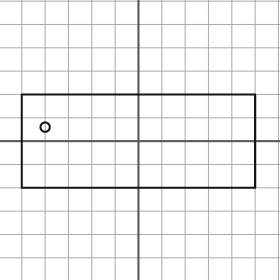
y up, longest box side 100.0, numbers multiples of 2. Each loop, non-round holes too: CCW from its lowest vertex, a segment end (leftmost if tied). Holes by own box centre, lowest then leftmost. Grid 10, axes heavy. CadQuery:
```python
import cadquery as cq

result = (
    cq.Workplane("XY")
    .moveTo(-50.0, -20.0)
    .lineTo(50.0, -20.0)
    .lineTo(50.0, 20.0)
    .lineTo(-50.0, 20.0)
    .close()
    .moveTo(-40.0, 6.0)
    .circle(2.0)
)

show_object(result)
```